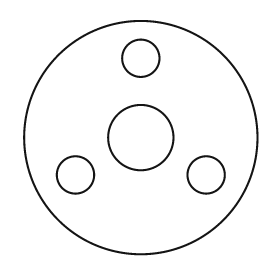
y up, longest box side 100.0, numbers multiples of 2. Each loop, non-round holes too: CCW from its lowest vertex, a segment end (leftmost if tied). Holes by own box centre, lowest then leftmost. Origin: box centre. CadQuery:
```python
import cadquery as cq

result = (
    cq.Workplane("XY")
    .moveTo(0.0, 0.0)
    .circle(50.0)
    .moveTo(-28.0, -16.0)
    .circle(8.0)
    .moveTo(28.0, -16.0)
    .circle(8.0)
    .moveTo(0.0, 0.0)
    .circle(14.0)
    .moveTo(0.0, 34.0)
    .circle(8.0)
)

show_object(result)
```